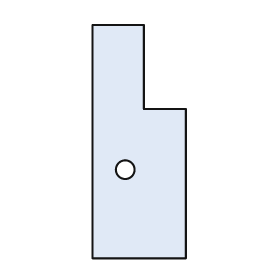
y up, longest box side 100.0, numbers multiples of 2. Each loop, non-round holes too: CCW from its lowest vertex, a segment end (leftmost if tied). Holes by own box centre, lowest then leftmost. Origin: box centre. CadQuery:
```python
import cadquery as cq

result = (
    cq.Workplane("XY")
    .moveTo(-20.0, -50.0)
    .lineTo(20.0, -50.0)
    .lineTo(20.0, 14.0)
    .lineTo(2.0, 14.0)
    .lineTo(2.0, 50.0)
    .lineTo(-20.0, 50.0)
    .close()
    .moveTo(-6.0, -12.0)
    .circle(4.0)
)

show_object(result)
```